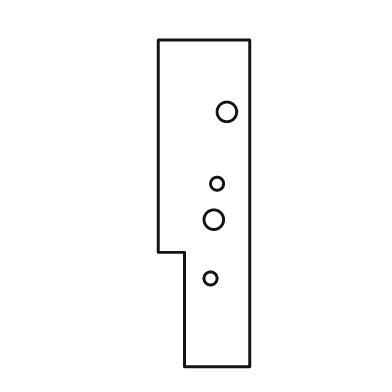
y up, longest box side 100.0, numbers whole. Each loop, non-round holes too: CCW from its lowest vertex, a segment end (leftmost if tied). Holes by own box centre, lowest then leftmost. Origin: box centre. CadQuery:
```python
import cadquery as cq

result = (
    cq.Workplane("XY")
    .moveTo(-6.0, -50.0)
    .lineTo(14.0, -50.0)
    .lineTo(14.0, 50.0)
    .lineTo(-14.0, 50.0)
    .lineTo(-14.0, -15.0)
    .lineTo(-6.0, -15.0)
    .close()
    .moveTo(2.0, -23.0)
    .circle(2.0)
    .moveTo(3.0, -5.0)
    .circle(3.0)
    .moveTo(4.0, 6.0)
    .circle(2.0)
    .moveTo(7.0, 28.0)
    .circle(3.0)
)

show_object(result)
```